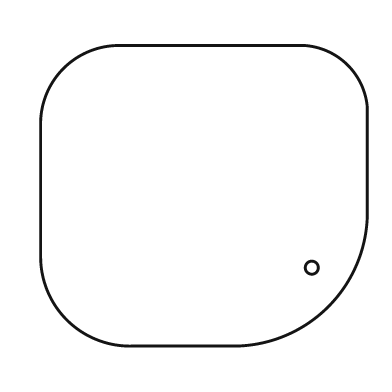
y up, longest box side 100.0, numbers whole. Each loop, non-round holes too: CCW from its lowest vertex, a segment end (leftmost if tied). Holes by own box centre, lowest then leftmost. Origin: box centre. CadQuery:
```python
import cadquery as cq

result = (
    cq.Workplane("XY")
    .moveTo(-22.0, -46.0)
    .lineTo(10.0, -46.0)
    .threePointArc((38.0, -34.0), (50.0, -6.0))
    .lineTo(50.0, 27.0)
    .threePointArc((44.0, 40.0), (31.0, 46.0))
    .lineTo(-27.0, 46.0)
    .threePointArc((-43.0, 39.0), (-50.0, 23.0))
    .lineTo(-50.0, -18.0)
    .threePointArc((-42.0, -38.0), (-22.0, -46.0))
    .close()
    .moveTo(33.0, -22.0)
    .circle(2.0)
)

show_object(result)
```